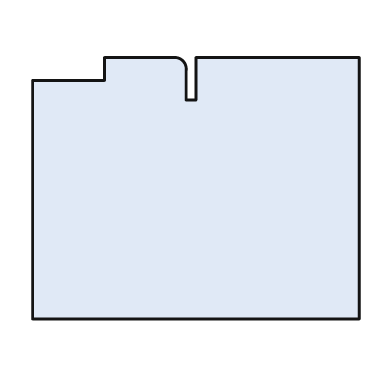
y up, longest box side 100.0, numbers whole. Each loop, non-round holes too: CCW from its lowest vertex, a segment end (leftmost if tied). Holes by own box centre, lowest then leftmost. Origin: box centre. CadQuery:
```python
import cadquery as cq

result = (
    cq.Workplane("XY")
    .moveTo(-50.0, -40.0)
    .lineTo(50.0, -40.0)
    .lineTo(50.0, 40.0)
    .lineTo(0.0, 40.0)
    .lineTo(0.0, 27.0)
    .lineTo(-3.0, 27.0)
    .lineTo(-3.0, 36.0)
    .threePointArc((-4.0, 39.0), (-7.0, 40.0))
    .lineTo(-28.0, 40.0)
    .lineTo(-28.0, 33.0)
    .lineTo(-50.0, 33.0)
    .close()
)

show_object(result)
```